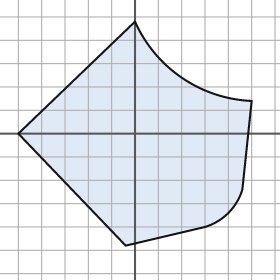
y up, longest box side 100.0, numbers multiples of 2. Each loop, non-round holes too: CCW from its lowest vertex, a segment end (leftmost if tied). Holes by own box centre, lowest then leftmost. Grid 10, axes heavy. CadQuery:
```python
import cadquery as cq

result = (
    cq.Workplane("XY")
    .moveTo(-4.0, -48.0)
    .lineTo(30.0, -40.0)
    .threePointArc((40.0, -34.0), (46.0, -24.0))
    .lineTo(50.0, 14.0)
    .threePointArc((20.0, 24.0), (0.0, 48.0))
    .lineTo(-50.0, 0.0)
    .close()
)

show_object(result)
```